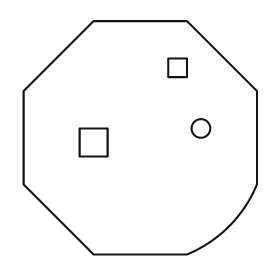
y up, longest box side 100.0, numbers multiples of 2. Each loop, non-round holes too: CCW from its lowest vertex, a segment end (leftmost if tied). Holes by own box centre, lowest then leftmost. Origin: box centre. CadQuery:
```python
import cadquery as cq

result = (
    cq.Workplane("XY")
    .moveTo(-20.0, -50.0)
    .lineTo(20.0, -50.0)
    .threePointArc((38.0, -38.0), (50.0, -20.0))
    .lineTo(50.0, 20.0)
    .lineTo(20.0, 50.0)
    .lineTo(-20.0, 50.0)
    .lineTo(-50.0, 20.0)
    .lineTo(-50.0, -20.0)
    .close()
    .moveTo(-26.0, -8.0)
    .lineTo(-14.0, -8.0)
    .lineTo(-14.0, 4.0)
    .lineTo(-26.0, 4.0)
    .close()
    .moveTo(26.0, 4.0)
    .circle(4.0)
    .moveTo(12.0, 26.0)
    .lineTo(20.0, 26.0)
    .lineTo(20.0, 34.0)
    .lineTo(12.0, 34.0)
    .close()
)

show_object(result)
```